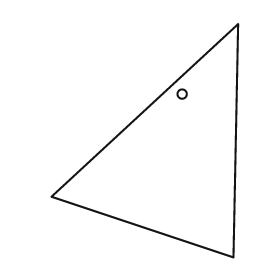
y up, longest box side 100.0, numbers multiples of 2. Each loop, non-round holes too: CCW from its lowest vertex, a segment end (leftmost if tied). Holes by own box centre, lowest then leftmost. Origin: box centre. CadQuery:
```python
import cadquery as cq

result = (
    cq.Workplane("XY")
    .moveTo(38.0, -50.0)
    .lineTo(40.0, 50.0)
    .lineTo(-40.0, -24.0)
    .close()
    .moveTo(16.0, 20.0)
    .circle(2.0)
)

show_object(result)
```